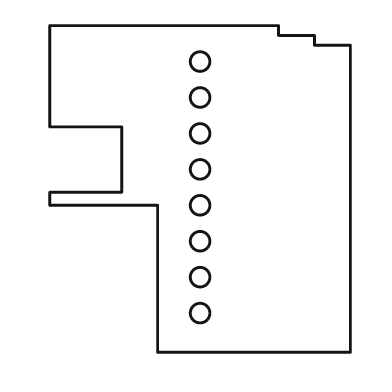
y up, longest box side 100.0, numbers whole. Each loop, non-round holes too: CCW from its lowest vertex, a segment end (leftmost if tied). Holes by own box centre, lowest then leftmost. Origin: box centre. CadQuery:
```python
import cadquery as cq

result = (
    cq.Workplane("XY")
    .moveTo(-13.0, -50.0)
    .lineTo(46.0, -50.0)
    .lineTo(46.0, 44.0)
    .lineTo(35.0, 44.0)
    .lineTo(35.0, 47.0)
    .lineTo(24.0, 47.0)
    .lineTo(24.0, 50.0)
    .lineTo(-46.0, 50.0)
    .lineTo(-46.0, 19.0)
    .lineTo(-24.0, 19.0)
    .lineTo(-24.0, -1.0)
    .lineTo(-46.0, -1.0)
    .lineTo(-46.0, -5.0)
    .lineTo(-13.0, -5.0)
    .close()
    .moveTo(0.0, -38.0)
    .circle(3.0)
    .moveTo(0.0, -27.0)
    .circle(3.0)
    .moveTo(0.0, -16.0)
    .circle(3.0)
    .moveTo(0.0, -5.0)
    .circle(3.0)
    .moveTo(0.0, 6.0)
    .circle(3.0)
    .moveTo(0.0, 17.0)
    .circle(3.0)
    .moveTo(0.0, 28.0)
    .circle(3.0)
    .moveTo(0.0, 39.0)
    .circle(3.0)
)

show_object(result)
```